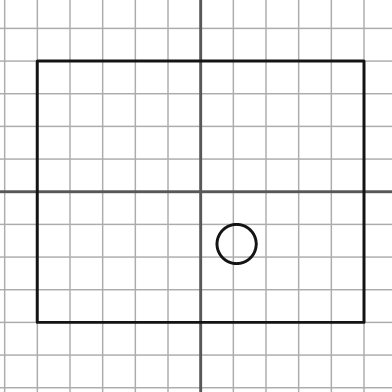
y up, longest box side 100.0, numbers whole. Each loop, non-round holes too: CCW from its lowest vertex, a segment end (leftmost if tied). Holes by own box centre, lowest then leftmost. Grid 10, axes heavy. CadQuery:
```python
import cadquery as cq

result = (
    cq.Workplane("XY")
    .moveTo(-50.0, -40.0)
    .lineTo(50.0, -40.0)
    .lineTo(50.0, 40.0)
    .lineTo(-50.0, 40.0)
    .close()
    .moveTo(11.0, -16.0)
    .circle(6.0)
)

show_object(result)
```